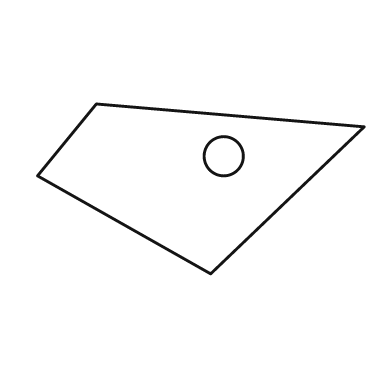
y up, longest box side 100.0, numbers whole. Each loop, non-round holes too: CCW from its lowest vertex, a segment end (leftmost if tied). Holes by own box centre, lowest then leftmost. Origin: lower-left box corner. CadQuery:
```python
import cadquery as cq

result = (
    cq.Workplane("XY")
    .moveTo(53.0, 0.0)
    .lineTo(100.0, 45.0)
    .lineTo(18.0, 52.0)
    .lineTo(0.0, 30.0)
    .close()
    .moveTo(57.0, 36.0)
    .circle(6.0)
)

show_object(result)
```